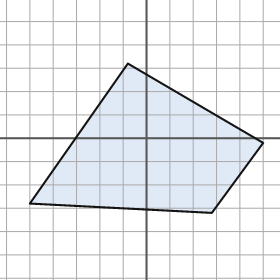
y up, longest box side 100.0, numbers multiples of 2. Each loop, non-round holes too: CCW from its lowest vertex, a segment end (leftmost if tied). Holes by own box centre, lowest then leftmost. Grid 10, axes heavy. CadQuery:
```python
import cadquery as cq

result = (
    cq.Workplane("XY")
    .moveTo(28.0, -32.0)
    .lineTo(50.0, -2.0)
    .lineTo(-8.0, 32.0)
    .lineTo(-50.0, -28.0)
    .close()
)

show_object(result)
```